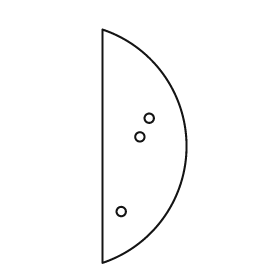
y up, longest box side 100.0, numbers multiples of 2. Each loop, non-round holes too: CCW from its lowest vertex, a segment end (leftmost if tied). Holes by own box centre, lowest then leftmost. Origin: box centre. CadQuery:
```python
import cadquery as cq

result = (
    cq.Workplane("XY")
    .moveTo(-18.0, -50.0)
    .threePointArc((18.0, 0.0), (-18.0, 50.0))
    .close()
    .moveTo(-10.0, -28.0)
    .circle(2.0)
    .moveTo(-2.0, 4.0)
    .circle(2.0)
    .moveTo(2.0, 12.0)
    .circle(2.0)
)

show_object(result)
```